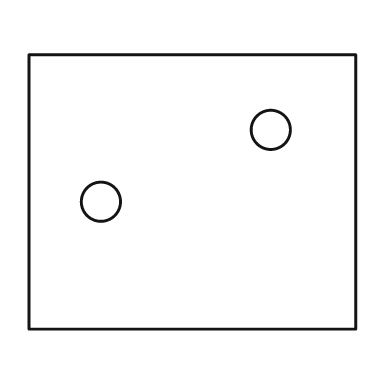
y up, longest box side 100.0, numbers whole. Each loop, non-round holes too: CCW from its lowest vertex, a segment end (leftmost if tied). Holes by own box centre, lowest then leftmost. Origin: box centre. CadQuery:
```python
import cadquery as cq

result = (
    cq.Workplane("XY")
    .moveTo(-50.0, -42.0)
    .lineTo(50.0, -42.0)
    .lineTo(50.0, 42.0)
    .lineTo(-50.0, 42.0)
    .close()
    .moveTo(-28.0, -3.0)
    .circle(6.0)
    .moveTo(24.0, 19.0)
    .circle(6.0)
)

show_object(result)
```